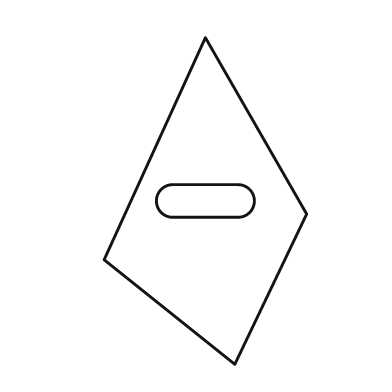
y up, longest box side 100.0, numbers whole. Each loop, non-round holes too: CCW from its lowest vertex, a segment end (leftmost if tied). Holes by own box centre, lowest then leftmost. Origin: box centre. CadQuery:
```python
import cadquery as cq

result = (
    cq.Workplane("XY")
    .moveTo(9.0, -50.0)
    .lineTo(31.0, -4.0)
    .lineTo(0.0, 50.0)
    .lineTo(-31.0, -18.0)
    .close()
    .moveTo(-10.0, -5.0)
    .lineTo(10.0, -5.0)
    .threePointArc((15.0, 0.0), (10.0, 5.0))
    .lineTo(-10.0, 5.0)
    .threePointArc((-15.0, 0.0), (-10.0, -5.0))
    .close()
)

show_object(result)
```